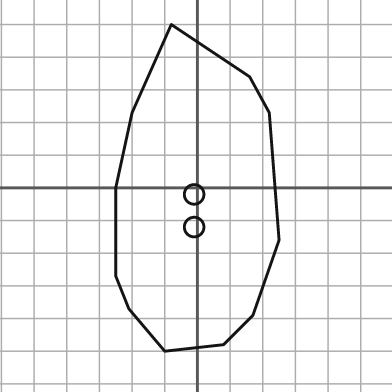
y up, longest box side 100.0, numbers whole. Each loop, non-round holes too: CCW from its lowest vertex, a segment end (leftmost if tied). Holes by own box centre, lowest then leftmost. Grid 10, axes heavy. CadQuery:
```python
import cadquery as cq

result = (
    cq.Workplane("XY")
    .moveTo(-10.0, -50.0)
    .lineTo(8.0, -48.0)
    .lineTo(17.0, -39.0)
    .lineTo(25.0, -16.0)
    .lineTo(22.0, 23.0)
    .lineTo(16.0, 34.0)
    .lineTo(-8.0, 50.0)
    .lineTo(-20.0, 23.0)
    .lineTo(-25.0, 0.0)
    .lineTo(-25.0, -27.0)
    .lineTo(-21.0, -37.0)
    .close()
    .moveTo(-1.0, -12.0)
    .circle(3.0)
    .moveTo(-1.0, -2.0)
    .circle(3.0)
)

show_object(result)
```